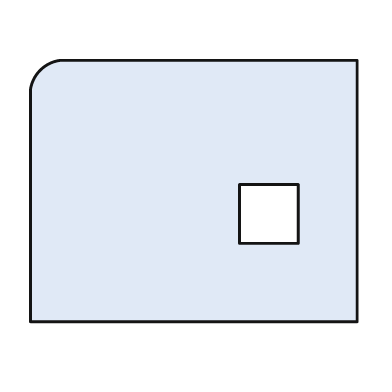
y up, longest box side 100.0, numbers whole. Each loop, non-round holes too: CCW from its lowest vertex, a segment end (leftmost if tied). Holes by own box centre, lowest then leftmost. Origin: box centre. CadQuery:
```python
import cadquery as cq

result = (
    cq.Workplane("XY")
    .moveTo(-50.0, -40.0)
    .lineTo(50.0, -40.0)
    .lineTo(50.0, 40.0)
    .lineTo(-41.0, 40.0)
    .threePointArc((-47.0, 37.0), (-50.0, 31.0))
    .close()
    .moveTo(14.0, -16.0)
    .lineTo(32.0, -16.0)
    .lineTo(32.0, 2.0)
    .lineTo(14.0, 2.0)
    .close()
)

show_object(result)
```